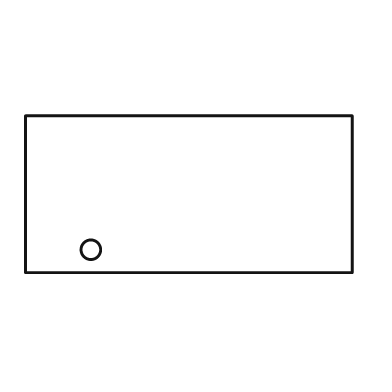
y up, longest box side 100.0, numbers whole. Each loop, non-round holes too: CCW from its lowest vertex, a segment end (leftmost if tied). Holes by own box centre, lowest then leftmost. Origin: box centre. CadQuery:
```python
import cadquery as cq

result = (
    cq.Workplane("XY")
    .moveTo(-50.0, -24.0)
    .lineTo(50.0, -24.0)
    .lineTo(50.0, 24.0)
    .lineTo(-50.0, 24.0)
    .close()
    .moveTo(-30.0, -17.0)
    .circle(3.0)
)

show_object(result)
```